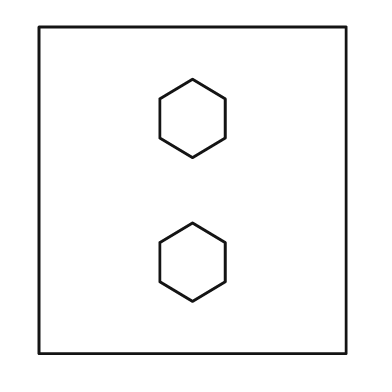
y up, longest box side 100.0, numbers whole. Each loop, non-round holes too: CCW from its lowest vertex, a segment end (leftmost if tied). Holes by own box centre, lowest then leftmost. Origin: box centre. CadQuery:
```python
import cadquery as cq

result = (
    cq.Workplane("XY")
    .moveTo(-47.0, -50.0)
    .lineTo(47.0, -50.0)
    .lineTo(47.0, 50.0)
    .lineTo(-47.0, 50.0)
    .close()
    .moveTo(0.0, -34.0)
    .lineTo(10.0, -28.0)
    .lineTo(10.0, -16.0)
    .lineTo(0.0, -10.0)
    .lineTo(-10.0, -16.0)
    .lineTo(-10.0, -28.0)
    .close()
    .moveTo(0.0, 10.0)
    .lineTo(10.0, 16.0)
    .lineTo(10.0, 28.0)
    .lineTo(0.0, 34.0)
    .lineTo(-10.0, 28.0)
    .lineTo(-10.0, 16.0)
    .close()
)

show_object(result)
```